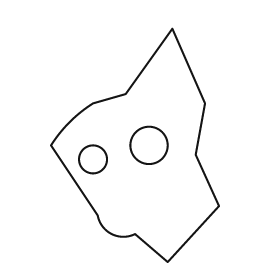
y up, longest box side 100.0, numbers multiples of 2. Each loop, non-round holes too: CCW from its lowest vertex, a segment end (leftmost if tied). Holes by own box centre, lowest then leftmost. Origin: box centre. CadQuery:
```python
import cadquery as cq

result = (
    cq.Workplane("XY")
    .moveTo(14.0, -50.0)
    .lineTo(36.0, -26.0)
    .lineTo(26.0, -4.0)
    .lineTo(30.0, 18.0)
    .lineTo(16.0, 50.0)
    .lineTo(-4.0, 22.0)
    .lineTo(-18.0, 18.0)
    .threePointArc((-28.0, 10.0), (-36.0, 0.0))
    .lineTo(-16.0, -30.0)
    .threePointArc((-10.0, -38.0), (0.0, -38.0))
    .close()
    .moveTo(-18.0, -6.0)
    .circle(6.0)
    .moveTo(6.0, 0.0)
    .circle(8.0)
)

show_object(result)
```